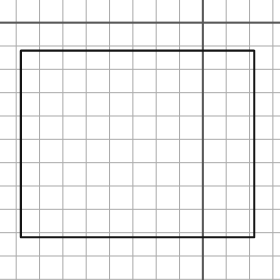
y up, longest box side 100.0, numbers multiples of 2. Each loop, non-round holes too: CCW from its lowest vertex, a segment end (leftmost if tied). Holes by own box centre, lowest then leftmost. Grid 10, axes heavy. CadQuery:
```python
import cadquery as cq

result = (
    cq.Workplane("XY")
    .moveTo(-78.0, -92.0)
    .lineTo(22.0, -92.0)
    .lineTo(22.0, -12.0)
    .lineTo(-78.0, -12.0)
    .close()
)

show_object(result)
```